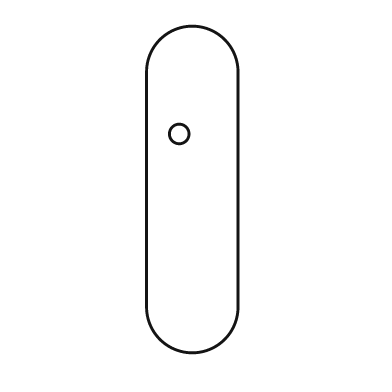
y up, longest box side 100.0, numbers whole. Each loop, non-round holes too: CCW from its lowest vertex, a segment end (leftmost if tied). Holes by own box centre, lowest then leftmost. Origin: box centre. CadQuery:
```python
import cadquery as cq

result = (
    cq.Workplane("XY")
    .moveTo(-14.0, -36.0)
    .threePointArc((0.0, -50.0), (14.0, -36.0))
    .lineTo(14.0, 36.0)
    .threePointArc((0.0, 50.0), (-14.0, 36.0))
    .close()
    .moveTo(-4.0, 17.0)
    .circle(3.0)
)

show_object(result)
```